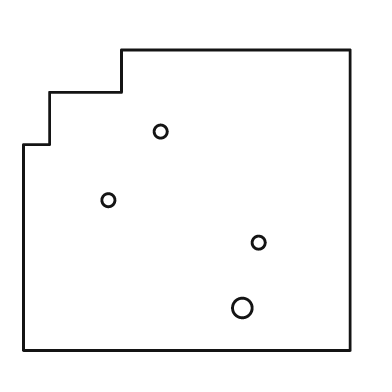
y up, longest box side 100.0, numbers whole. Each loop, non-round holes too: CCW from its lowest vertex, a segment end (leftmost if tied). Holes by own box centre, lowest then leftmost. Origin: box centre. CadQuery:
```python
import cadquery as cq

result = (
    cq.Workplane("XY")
    .moveTo(-50.0, -46.0)
    .lineTo(50.0, -46.0)
    .lineTo(50.0, 46.0)
    .lineTo(-20.0, 46.0)
    .lineTo(-20.0, 33.0)
    .lineTo(-42.0, 33.0)
    .lineTo(-42.0, 17.0)
    .lineTo(-50.0, 17.0)
    .close()
    .moveTo(17.0, -33.0)
    .circle(3.0)
    .moveTo(22.0, -13.0)
    .circle(2.0)
    .moveTo(-24.0, 0.0)
    .circle(2.0)
    .moveTo(-8.0, 21.0)
    .circle(2.0)
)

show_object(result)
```